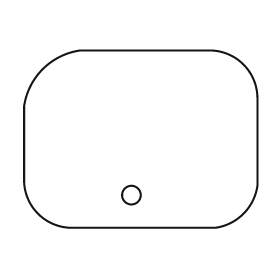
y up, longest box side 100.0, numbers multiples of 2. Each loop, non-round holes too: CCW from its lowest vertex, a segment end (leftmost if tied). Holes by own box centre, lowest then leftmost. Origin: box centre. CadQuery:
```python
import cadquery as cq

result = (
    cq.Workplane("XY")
    .moveTo(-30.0, -38.0)
    .lineTo(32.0, -38.0)
    .threePointArc((44.0, -32.0), (50.0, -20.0))
    .lineTo(50.0, 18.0)
    .threePointArc((44.0, 32.0), (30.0, 38.0))
    .lineTo(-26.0, 38.0)
    .threePointArc((-42.0, 30.0), (-50.0, 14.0))
    .lineTo(-50.0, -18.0)
    .threePointArc((-44.0, -32.0), (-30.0, -38.0))
    .close()
    .moveTo(-4.0, -24.0)
    .circle(4.0)
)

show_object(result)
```